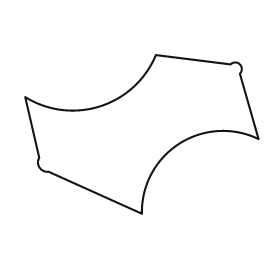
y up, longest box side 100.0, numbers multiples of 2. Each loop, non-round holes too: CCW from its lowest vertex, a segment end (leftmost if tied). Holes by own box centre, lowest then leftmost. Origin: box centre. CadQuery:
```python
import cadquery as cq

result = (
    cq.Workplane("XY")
    .moveTo(0.0, -34.0)
    .threePointArc((16.0, -4.0), (50.0, -2.0))
    .lineTo(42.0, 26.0)
    .threePointArc((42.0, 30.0), (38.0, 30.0))
    .lineTo(6.0, 34.0)
    .threePointArc((-18.0, 12.0), (-50.0, 16.0))
    .lineTo(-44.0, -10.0)
    .threePointArc((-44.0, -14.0), (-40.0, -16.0))
    .close()
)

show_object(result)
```